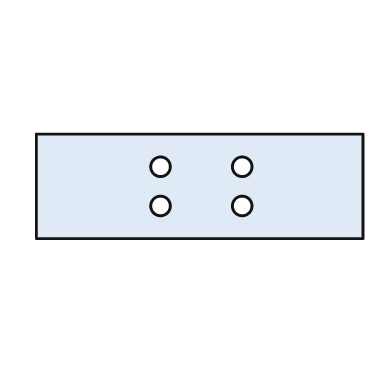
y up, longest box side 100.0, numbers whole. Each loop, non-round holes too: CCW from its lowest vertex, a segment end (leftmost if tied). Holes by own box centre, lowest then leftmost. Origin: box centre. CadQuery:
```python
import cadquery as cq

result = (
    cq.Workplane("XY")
    .moveTo(-50.0, -16.0)
    .lineTo(50.0, -16.0)
    .lineTo(50.0, 16.0)
    .lineTo(-50.0, 16.0)
    .close()
    .moveTo(-12.0, -6.0)
    .circle(3.0)
    .moveTo(13.0, -6.0)
    .circle(3.0)
    .moveTo(-12.0, 6.0)
    .circle(3.0)
    .moveTo(13.0, 6.0)
    .circle(3.0)
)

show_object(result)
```